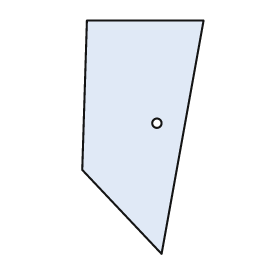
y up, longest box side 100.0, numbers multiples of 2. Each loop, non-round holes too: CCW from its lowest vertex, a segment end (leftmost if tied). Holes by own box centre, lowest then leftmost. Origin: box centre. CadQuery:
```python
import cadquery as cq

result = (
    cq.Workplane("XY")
    .moveTo(8.0, -50.0)
    .lineTo(26.0, 50.0)
    .lineTo(-24.0, 50.0)
    .lineTo(-26.0, -14.0)
    .close()
    .moveTo(6.0, 6.0)
    .circle(2.0)
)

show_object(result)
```